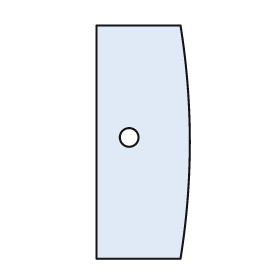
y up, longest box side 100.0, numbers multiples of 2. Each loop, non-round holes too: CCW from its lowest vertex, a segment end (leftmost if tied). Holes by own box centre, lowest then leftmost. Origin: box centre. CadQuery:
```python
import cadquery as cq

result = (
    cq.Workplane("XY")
    .moveTo(-20.0, -50.0)
    .lineTo(16.0, -50.0)
    .threePointArc((20.0, 0.0), (16.0, 50.0))
    .lineTo(-20.0, 50.0)
    .close()
    .moveTo(-6.0, 2.0)
    .circle(4.0)
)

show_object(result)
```